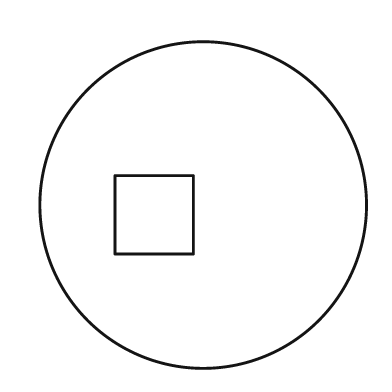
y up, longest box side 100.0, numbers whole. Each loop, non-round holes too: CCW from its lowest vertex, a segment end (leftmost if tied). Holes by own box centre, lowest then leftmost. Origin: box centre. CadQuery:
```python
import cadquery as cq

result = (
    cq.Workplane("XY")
    .moveTo(0.0, 0.0)
    .circle(50.0)
    .moveTo(-27.0, -15.0)
    .lineTo(-3.0, -15.0)
    .lineTo(-3.0, 9.0)
    .lineTo(-27.0, 9.0)
    .close()
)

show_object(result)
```